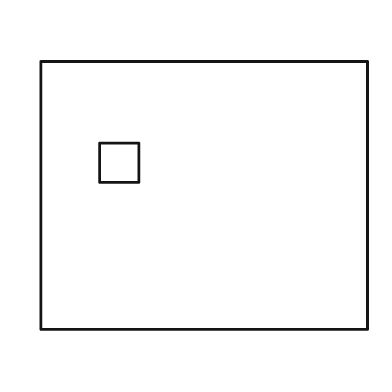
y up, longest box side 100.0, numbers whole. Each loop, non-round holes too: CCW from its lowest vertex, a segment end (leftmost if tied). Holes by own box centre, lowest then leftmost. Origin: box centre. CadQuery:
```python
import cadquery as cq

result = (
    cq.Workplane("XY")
    .moveTo(-50.0, -41.0)
    .lineTo(50.0, -41.0)
    .lineTo(50.0, 41.0)
    .lineTo(-50.0, 41.0)
    .close()
    .moveTo(-32.0, 4.0)
    .lineTo(-20.0, 4.0)
    .lineTo(-20.0, 16.0)
    .lineTo(-32.0, 16.0)
    .close()
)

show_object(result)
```